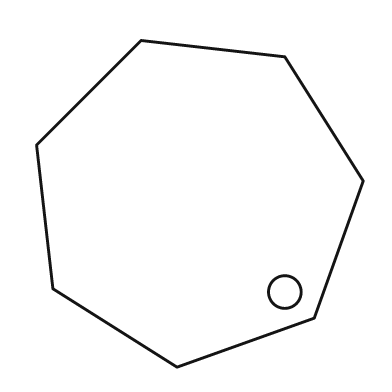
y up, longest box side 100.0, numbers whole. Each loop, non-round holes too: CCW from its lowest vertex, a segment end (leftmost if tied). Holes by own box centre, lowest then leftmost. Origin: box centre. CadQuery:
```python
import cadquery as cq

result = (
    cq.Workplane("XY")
    .moveTo(-7.0, -50.0)
    .lineTo(35.0, -35.0)
    .lineTo(50.0, 7.0)
    .lineTo(26.0, 45.0)
    .lineTo(-18.0, 50.0)
    .lineTo(-50.0, 18.0)
    .lineTo(-45.0, -26.0)
    .close()
    .moveTo(26.0, -27.0)
    .circle(5.0)
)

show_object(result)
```